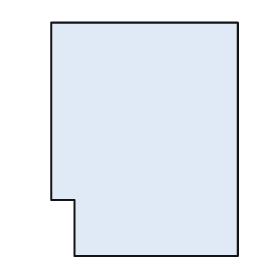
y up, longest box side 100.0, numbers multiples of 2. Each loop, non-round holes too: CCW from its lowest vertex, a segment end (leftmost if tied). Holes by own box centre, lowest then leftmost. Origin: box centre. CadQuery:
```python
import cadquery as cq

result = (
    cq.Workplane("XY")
    .moveTo(-30.0, -50.0)
    .lineTo(40.0, -50.0)
    .lineTo(40.0, 50.0)
    .lineTo(-40.0, 50.0)
    .lineTo(-40.0, -26.0)
    .lineTo(-30.0, -26.0)
    .close()
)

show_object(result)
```